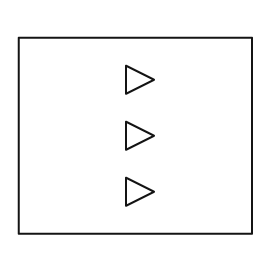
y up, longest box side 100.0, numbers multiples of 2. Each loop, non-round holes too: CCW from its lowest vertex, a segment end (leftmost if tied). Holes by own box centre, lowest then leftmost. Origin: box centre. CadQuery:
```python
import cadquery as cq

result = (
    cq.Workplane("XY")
    .moveTo(-50.0, -42.0)
    .lineTo(50.0, -42.0)
    .lineTo(50.0, 42.0)
    .lineTo(-50.0, 42.0)
    .close()
    .moveTo(-4.0, -30.0)
    .lineTo(8.0, -24.0)
    .lineTo(-4.0, -18.0)
    .close()
    .moveTo(-4.0, -6.0)
    .lineTo(8.0, 0.0)
    .lineTo(-4.0, 6.0)
    .close()
    .moveTo(-4.0, 18.0)
    .lineTo(8.0, 24.0)
    .lineTo(-4.0, 30.0)
    .close()
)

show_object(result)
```